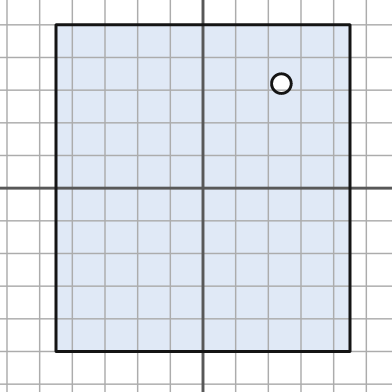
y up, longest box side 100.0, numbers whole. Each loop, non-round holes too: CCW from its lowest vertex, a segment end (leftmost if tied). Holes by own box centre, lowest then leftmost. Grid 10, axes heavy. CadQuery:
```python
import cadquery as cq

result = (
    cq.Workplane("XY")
    .moveTo(-45.0, -50.0)
    .lineTo(45.0, -50.0)
    .lineTo(45.0, 50.0)
    .lineTo(-45.0, 50.0)
    .close()
    .moveTo(24.0, 32.0)
    .circle(3.0)
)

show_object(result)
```